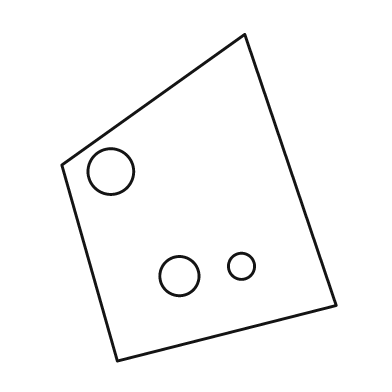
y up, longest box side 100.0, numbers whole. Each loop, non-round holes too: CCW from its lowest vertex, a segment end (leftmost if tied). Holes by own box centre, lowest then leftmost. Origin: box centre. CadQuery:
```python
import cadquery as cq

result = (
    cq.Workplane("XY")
    .moveTo(-25.0, -50.0)
    .lineTo(42.0, -33.0)
    .lineTo(14.0, 50.0)
    .lineTo(-42.0, 10.0)
    .close()
    .moveTo(-6.0, -24.0)
    .circle(6.0)
    .moveTo(13.0, -21.0)
    .circle(4.0)
    .moveTo(-27.0, 8.0)
    .circle(7.0)
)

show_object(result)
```